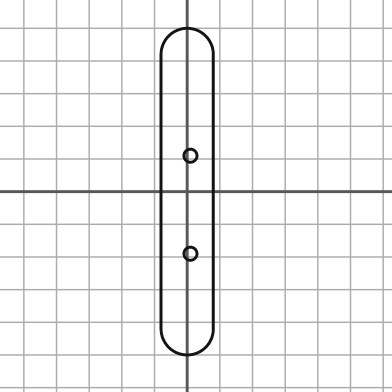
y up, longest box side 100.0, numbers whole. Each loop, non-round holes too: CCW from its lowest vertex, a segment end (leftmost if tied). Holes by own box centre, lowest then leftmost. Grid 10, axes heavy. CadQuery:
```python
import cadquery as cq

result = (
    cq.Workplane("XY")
    .moveTo(-8.0, -42.0)
    .threePointArc((0.0, -50.0), (8.0, -42.0))
    .lineTo(8.0, 42.0)
    .threePointArc((0.0, 50.0), (-8.0, 42.0))
    .close()
    .moveTo(1.0, -19.0)
    .circle(2.0)
    .moveTo(1.0, 11.0)
    .circle(2.0)
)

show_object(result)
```